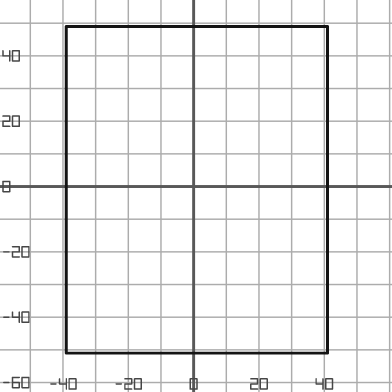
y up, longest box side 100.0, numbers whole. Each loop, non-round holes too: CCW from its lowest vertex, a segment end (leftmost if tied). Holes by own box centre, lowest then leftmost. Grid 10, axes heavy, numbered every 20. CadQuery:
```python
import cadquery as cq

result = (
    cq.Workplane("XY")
    .moveTo(-39.0, -51.0)
    .lineTo(41.0, -51.0)
    .lineTo(41.0, 49.0)
    .lineTo(-39.0, 49.0)
    .close()
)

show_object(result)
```